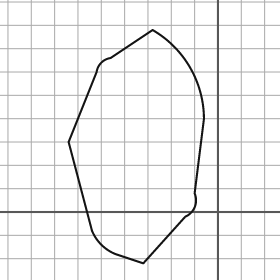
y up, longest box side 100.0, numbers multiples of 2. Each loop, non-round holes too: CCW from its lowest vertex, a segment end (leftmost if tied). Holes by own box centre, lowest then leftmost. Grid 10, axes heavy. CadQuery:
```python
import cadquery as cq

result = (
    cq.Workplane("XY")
    .moveTo(-32.0, -22.0)
    .lineTo(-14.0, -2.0)
    .threePointArc((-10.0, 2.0), (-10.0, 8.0))
    .lineTo(-6.0, 40.0)
    .threePointArc((-12.0, 62.0), (-28.0, 78.0))
    .lineTo(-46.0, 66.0)
    .threePointArc((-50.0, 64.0), (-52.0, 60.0))
    .lineTo(-64.0, 30.0)
    .lineTo(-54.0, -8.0)
    .threePointArc((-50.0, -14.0), (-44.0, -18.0))
    .close()
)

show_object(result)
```